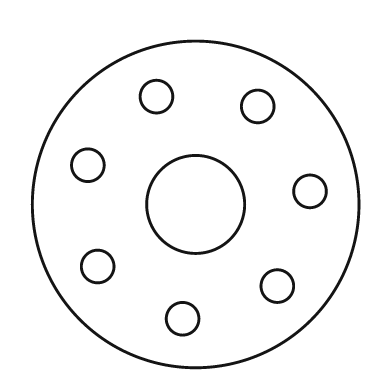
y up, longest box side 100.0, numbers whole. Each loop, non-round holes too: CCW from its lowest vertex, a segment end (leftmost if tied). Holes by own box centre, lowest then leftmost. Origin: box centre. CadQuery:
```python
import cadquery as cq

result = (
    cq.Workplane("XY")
    .moveTo(0.0, 0.0)
    .circle(50.0)
    .moveTo(-4.0, -35.0)
    .circle(5.0)
    .moveTo(25.0, -25.0)
    .circle(5.0)
    .moveTo(-30.0, -19.0)
    .circle(5.0)
    .moveTo(0.0, 0.0)
    .circle(15.0)
    .moveTo(35.0, 4.0)
    .circle(5.0)
    .moveTo(-33.0, 12.0)
    .circle(5.0)
    .moveTo(19.0, 30.0)
    .circle(5.0)
    .moveTo(-12.0, 33.0)
    .circle(5.0)
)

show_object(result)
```